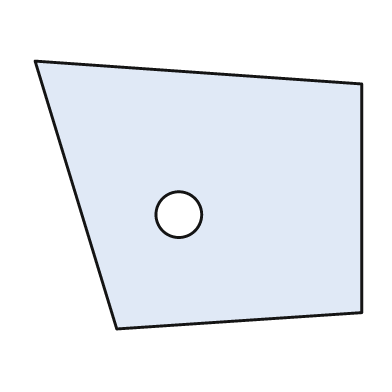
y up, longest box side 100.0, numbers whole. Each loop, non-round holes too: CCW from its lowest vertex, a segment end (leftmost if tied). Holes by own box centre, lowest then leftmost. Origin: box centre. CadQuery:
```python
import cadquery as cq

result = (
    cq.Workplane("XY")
    .moveTo(-25.0, -41.0)
    .lineTo(50.0, -36.0)
    .lineTo(50.0, 34.0)
    .lineTo(-50.0, 41.0)
    .close()
    .moveTo(-6.0, -6.0)
    .circle(7.0)
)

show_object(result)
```